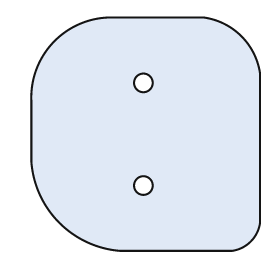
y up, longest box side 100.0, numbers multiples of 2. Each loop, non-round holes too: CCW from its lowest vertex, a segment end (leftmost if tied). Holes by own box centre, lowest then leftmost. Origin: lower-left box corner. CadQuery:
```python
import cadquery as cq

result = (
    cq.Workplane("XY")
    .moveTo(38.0, 0.0)
    .lineTo(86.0, 0.0)
    .threePointArc((94.0, 4.0), (98.0, 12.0))
    .lineTo(98.0, 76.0)
    .threePointArc((90.0, 92.0), (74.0, 100.0))
    .lineTo(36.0, 100.0)
    .threePointArc((10.0, 90.0), (0.0, 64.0))
    .lineTo(0.0, 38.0)
    .threePointArc((12.0, 12.0), (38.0, 0.0))
    .close()
    .moveTo(48.0, 28.0)
    .circle(4.0)
    .moveTo(48.0, 72.0)
    .circle(4.0)
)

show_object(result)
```